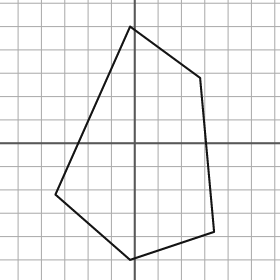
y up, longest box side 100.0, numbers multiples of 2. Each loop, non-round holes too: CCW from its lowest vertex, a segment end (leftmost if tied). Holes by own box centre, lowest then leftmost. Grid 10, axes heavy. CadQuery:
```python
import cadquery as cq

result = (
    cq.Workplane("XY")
    .moveTo(-2.0, -50.0)
    .lineTo(34.0, -38.0)
    .lineTo(28.0, 28.0)
    .lineTo(-2.0, 50.0)
    .lineTo(-34.0, -22.0)
    .close()
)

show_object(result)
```